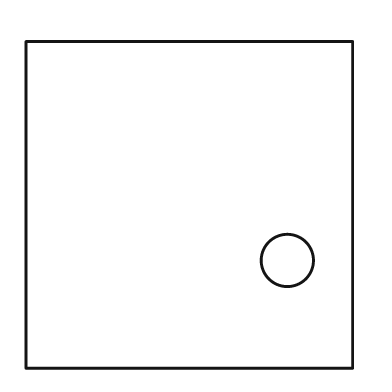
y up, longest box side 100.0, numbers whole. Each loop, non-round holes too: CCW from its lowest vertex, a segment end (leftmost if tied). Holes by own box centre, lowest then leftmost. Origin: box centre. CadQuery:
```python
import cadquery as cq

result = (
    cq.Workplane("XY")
    .moveTo(-50.0, -50.0)
    .lineTo(50.0, -50.0)
    .lineTo(50.0, 50.0)
    .lineTo(-50.0, 50.0)
    .close()
    .moveTo(30.0, -17.0)
    .circle(8.0)
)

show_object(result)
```